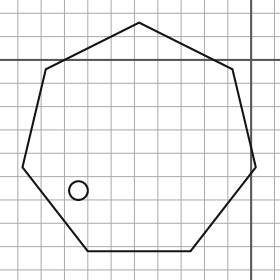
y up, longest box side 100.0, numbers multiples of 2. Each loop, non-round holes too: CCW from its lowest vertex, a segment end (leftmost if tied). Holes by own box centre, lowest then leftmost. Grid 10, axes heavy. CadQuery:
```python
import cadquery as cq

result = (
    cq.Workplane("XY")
    .moveTo(-70.0, -82.0)
    .lineTo(-26.0, -82.0)
    .lineTo(2.0, -46.0)
    .lineTo(-8.0, -4.0)
    .lineTo(-48.0, 16.0)
    .lineTo(-88.0, -4.0)
    .lineTo(-98.0, -46.0)
    .close()
    .moveTo(-74.0, -56.0)
    .circle(4.0)
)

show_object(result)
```